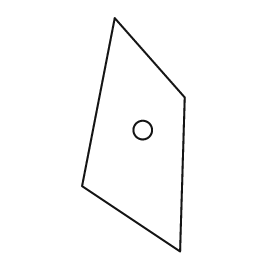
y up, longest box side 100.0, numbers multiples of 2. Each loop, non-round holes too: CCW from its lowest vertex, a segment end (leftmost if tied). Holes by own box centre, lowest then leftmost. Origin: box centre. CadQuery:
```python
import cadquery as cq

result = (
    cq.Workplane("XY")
    .moveTo(20.0, -50.0)
    .lineTo(22.0, 16.0)
    .lineTo(-8.0, 50.0)
    .lineTo(-22.0, -22.0)
    .close()
    .moveTo(4.0, 2.0)
    .circle(4.0)
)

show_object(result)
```